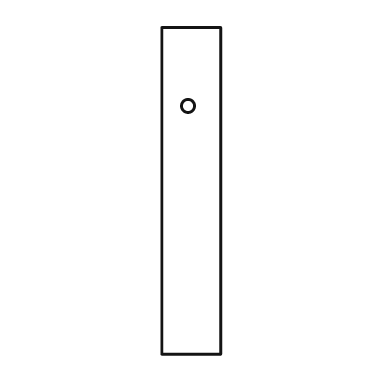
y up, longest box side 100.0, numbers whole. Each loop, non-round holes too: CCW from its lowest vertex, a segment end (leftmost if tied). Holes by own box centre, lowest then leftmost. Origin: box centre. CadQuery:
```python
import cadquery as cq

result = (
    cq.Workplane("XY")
    .moveTo(-9.0, -50.0)
    .lineTo(9.0, -50.0)
    .lineTo(9.0, 50.0)
    .lineTo(-9.0, 50.0)
    .close()
    .moveTo(-1.0, 26.0)
    .circle(2.0)
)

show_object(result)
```